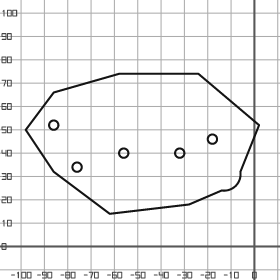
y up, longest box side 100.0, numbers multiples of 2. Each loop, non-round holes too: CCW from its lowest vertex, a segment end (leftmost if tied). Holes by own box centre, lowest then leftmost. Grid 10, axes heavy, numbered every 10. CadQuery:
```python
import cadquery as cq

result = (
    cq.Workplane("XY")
    .moveTo(-62.0, 14.0)
    .lineTo(-28.0, 18.0)
    .lineTo(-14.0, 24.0)
    .threePointArc((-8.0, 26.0), (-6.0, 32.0))
    .lineTo(2.0, 52.0)
    .lineTo(-24.0, 74.0)
    .lineTo(-58.0, 74.0)
    .lineTo(-86.0, 66.0)
    .lineTo(-98.0, 50.0)
    .lineTo(-86.0, 32.0)
    .close()
    .moveTo(-76.0, 34.0)
    .circle(2.0)
    .moveTo(-56.0, 40.0)
    .circle(2.0)
    .moveTo(-32.0, 40.0)
    .circle(2.0)
    .moveTo(-18.0, 46.0)
    .circle(2.0)
    .moveTo(-86.0, 52.0)
    .circle(2.0)
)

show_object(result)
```